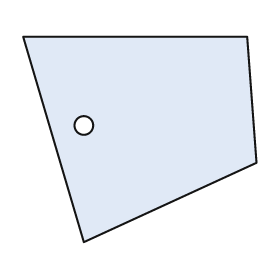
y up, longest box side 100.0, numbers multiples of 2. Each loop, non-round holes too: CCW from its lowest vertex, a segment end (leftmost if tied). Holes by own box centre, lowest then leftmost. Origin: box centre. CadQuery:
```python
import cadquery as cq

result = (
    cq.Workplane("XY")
    .moveTo(-24.0, -44.0)
    .lineTo(50.0, -10.0)
    .lineTo(46.0, 44.0)
    .lineTo(-50.0, 44.0)
    .close()
    .moveTo(-24.0, 6.0)
    .circle(4.0)
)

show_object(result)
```